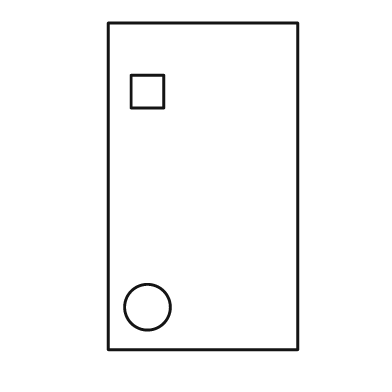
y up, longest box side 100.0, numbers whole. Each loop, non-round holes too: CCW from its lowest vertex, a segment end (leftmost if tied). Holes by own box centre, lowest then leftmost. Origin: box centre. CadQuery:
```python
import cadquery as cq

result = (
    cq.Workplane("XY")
    .moveTo(-29.0, -50.0)
    .lineTo(29.0, -50.0)
    .lineTo(29.0, 50.0)
    .lineTo(-29.0, 50.0)
    .close()
    .moveTo(-17.0, -37.0)
    .circle(7.0)
    .moveTo(-22.0, 24.0)
    .lineTo(-12.0, 24.0)
    .lineTo(-12.0, 34.0)
    .lineTo(-22.0, 34.0)
    .close()
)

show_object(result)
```